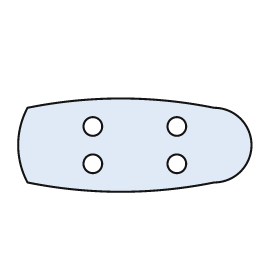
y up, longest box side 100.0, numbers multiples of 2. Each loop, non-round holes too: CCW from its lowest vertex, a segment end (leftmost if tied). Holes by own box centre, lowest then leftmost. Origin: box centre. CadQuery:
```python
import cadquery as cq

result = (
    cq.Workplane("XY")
    .moveTo(-46.0, -16.0)
    .threePointArc((-6.0, -20.0), (34.0, -16.0))
    .threePointArc((50.0, 0.0), (34.0, 16.0))
    .threePointArc((-6.0, 20.0), (-46.0, 16.0))
    .threePointArc((-50.0, 0.0), (-46.0, -16.0))
    .close()
    .moveTo(-18.0, -8.0)
    .circle(4.0)
    .moveTo(18.0, -8.0)
    .circle(4.0)
    .moveTo(-18.0, 8.0)
    .circle(4.0)
    .moveTo(18.0, 8.0)
    .circle(4.0)
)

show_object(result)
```